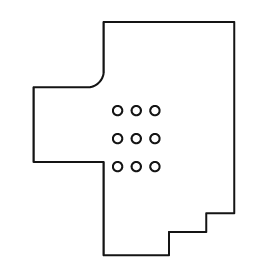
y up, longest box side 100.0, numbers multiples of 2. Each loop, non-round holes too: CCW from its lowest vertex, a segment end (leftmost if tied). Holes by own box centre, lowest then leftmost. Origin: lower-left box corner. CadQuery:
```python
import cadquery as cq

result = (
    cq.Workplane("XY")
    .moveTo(30.0, 0.0)
    .lineTo(58.0, 0.0)
    .lineTo(58.0, 10.0)
    .lineTo(74.0, 10.0)
    .lineTo(74.0, 18.0)
    .lineTo(86.0, 18.0)
    .lineTo(86.0, 100.0)
    .lineTo(30.0, 100.0)
    .lineTo(30.0, 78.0)
    .threePointArc((28.0, 74.0), (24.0, 72.0))
    .lineTo(0.0, 72.0)
    .lineTo(0.0, 40.0)
    .lineTo(30.0, 40.0)
    .close()
    .moveTo(36.0, 38.0)
    .circle(2.0)
    .moveTo(44.0, 38.0)
    .circle(2.0)
    .moveTo(52.0, 38.0)
    .circle(2.0)
    .moveTo(36.0, 50.0)
    .circle(2.0)
    .moveTo(44.0, 50.0)
    .circle(2.0)
    .moveTo(52.0, 50.0)
    .circle(2.0)
    .moveTo(36.0, 62.0)
    .circle(2.0)
    .moveTo(44.0, 62.0)
    .circle(2.0)
    .moveTo(52.0, 62.0)
    .circle(2.0)
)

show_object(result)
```